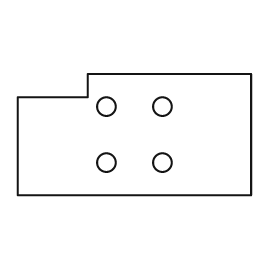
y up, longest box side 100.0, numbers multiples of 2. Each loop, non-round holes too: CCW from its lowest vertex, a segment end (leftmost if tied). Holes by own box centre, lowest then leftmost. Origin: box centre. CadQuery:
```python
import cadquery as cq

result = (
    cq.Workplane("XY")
    .moveTo(-50.0, -26.0)
    .lineTo(50.0, -26.0)
    .lineTo(50.0, 26.0)
    .lineTo(-20.0, 26.0)
    .lineTo(-20.0, 16.0)
    .lineTo(-50.0, 16.0)
    .close()
    .moveTo(-12.0, -12.0)
    .circle(4.0)
    .moveTo(12.0, -12.0)
    .circle(4.0)
    .moveTo(-12.0, 12.0)
    .circle(4.0)
    .moveTo(12.0, 12.0)
    .circle(4.0)
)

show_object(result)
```